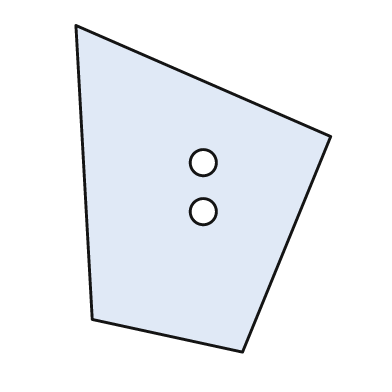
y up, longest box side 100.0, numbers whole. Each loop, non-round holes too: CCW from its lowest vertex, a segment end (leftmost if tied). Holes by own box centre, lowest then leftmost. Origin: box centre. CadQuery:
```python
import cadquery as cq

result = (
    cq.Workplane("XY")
    .moveTo(12.0, -50.0)
    .lineTo(39.0, 16.0)
    .lineTo(-39.0, 50.0)
    .lineTo(-34.0, -40.0)
    .close()
    .moveTo(0.0, -7.0)
    .circle(4.0)
    .moveTo(0.0, 8.0)
    .circle(4.0)
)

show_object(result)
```